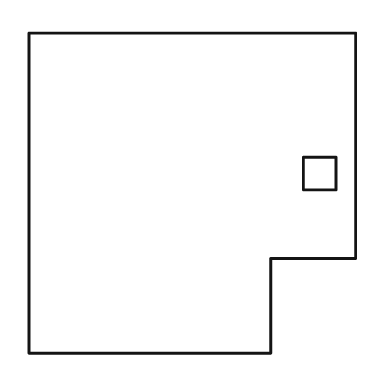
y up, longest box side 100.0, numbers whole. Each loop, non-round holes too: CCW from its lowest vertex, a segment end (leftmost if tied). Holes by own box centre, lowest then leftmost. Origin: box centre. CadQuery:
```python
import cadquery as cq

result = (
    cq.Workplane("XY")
    .moveTo(-50.0, -49.0)
    .lineTo(24.0, -49.0)
    .lineTo(24.0, -20.0)
    .lineTo(50.0, -20.0)
    .lineTo(50.0, 49.0)
    .lineTo(-50.0, 49.0)
    .close()
    .moveTo(34.0, 1.0)
    .lineTo(44.0, 1.0)
    .lineTo(44.0, 11.0)
    .lineTo(34.0, 11.0)
    .close()
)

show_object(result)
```